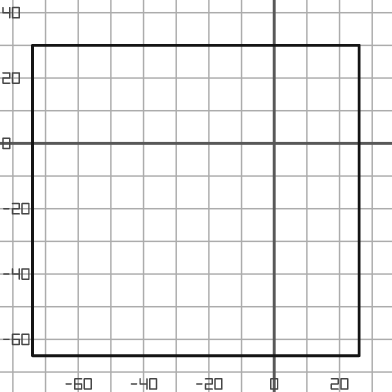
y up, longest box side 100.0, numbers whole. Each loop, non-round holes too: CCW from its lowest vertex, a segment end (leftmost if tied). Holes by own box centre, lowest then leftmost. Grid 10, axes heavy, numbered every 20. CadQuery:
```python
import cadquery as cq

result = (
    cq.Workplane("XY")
    .moveTo(-74.0, -65.0)
    .lineTo(26.0, -65.0)
    .lineTo(26.0, 30.0)
    .lineTo(-74.0, 30.0)
    .close()
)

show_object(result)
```